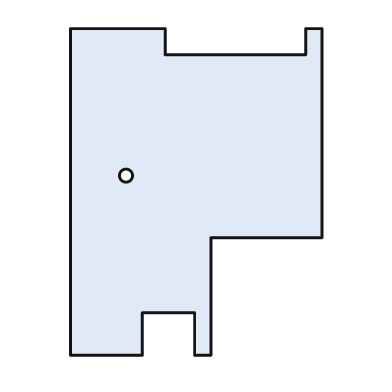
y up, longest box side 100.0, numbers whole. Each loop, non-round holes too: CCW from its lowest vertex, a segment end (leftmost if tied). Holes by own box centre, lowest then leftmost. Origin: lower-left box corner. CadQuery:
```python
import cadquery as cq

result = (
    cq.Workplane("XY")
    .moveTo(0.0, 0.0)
    .lineTo(22.0, 0.0)
    .lineTo(22.0, 13.0)
    .lineTo(38.0, 13.0)
    .lineTo(38.0, 0.0)
    .lineTo(43.0, 0.0)
    .lineTo(43.0, 36.0)
    .lineTo(77.0, 36.0)
    .lineTo(77.0, 100.0)
    .lineTo(72.0, 100.0)
    .lineTo(72.0, 92.0)
    .lineTo(29.0, 92.0)
    .lineTo(29.0, 100.0)
    .lineTo(0.0, 100.0)
    .close()
    .moveTo(17.0, 55.0)
    .circle(2.0)
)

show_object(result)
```